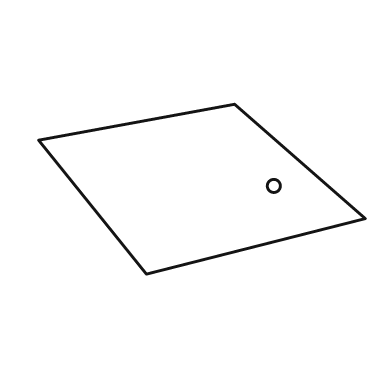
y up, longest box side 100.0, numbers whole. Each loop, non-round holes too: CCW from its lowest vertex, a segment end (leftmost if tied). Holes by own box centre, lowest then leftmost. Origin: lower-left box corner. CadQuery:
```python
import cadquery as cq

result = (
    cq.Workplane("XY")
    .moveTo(33.0, 0.0)
    .lineTo(100.0, 17.0)
    .lineTo(60.0, 52.0)
    .lineTo(0.0, 41.0)
    .close()
    .moveTo(72.0, 27.0)
    .circle(2.0)
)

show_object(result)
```